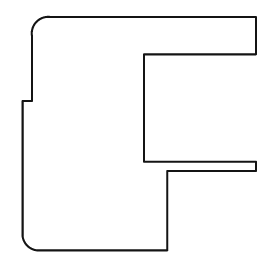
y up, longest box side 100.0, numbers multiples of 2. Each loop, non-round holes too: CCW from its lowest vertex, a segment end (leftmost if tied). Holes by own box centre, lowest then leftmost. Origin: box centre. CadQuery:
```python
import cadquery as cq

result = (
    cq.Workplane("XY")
    .moveTo(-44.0, -50.0)
    .lineTo(12.0, -50.0)
    .lineTo(12.0, -16.0)
    .lineTo(50.0, -16.0)
    .lineTo(50.0, -12.0)
    .lineTo(2.0, -12.0)
    .lineTo(2.0, 34.0)
    .lineTo(50.0, 34.0)
    .lineTo(50.0, 50.0)
    .lineTo(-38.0, 50.0)
    .threePointArc((-44.0, 48.0), (-46.0, 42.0))
    .lineTo(-46.0, 14.0)
    .lineTo(-50.0, 14.0)
    .lineTo(-50.0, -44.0)
    .threePointArc((-48.0, -48.0), (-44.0, -50.0))
    .close()
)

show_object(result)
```